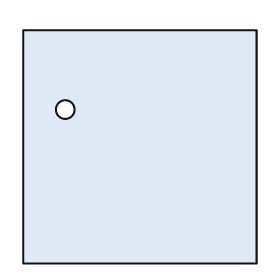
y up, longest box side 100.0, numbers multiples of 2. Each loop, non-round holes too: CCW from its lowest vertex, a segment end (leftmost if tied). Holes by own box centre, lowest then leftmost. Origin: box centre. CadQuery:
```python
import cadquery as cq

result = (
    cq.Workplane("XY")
    .moveTo(-50.0, -50.0)
    .lineTo(50.0, -50.0)
    .lineTo(50.0, 50.0)
    .lineTo(-50.0, 50.0)
    .close()
    .moveTo(-32.0, 16.0)
    .circle(4.0)
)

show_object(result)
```